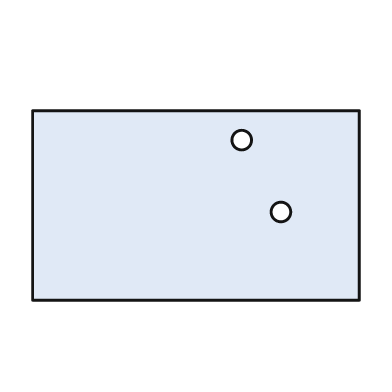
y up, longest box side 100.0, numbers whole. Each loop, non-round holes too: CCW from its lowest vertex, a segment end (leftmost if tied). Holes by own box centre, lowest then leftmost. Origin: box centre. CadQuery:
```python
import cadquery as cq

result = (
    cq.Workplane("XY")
    .moveTo(-50.0, -29.0)
    .lineTo(50.0, -29.0)
    .lineTo(50.0, 29.0)
    .lineTo(-50.0, 29.0)
    .close()
    .moveTo(26.0, -2.0)
    .circle(3.0)
    .moveTo(14.0, 20.0)
    .circle(3.0)
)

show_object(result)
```